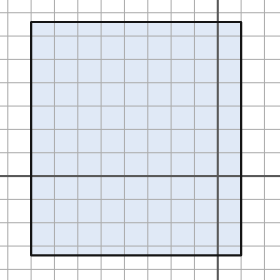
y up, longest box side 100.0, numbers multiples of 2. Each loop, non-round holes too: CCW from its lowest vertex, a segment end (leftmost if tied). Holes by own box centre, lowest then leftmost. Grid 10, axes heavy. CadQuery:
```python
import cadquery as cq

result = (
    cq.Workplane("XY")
    .moveTo(-80.0, -34.0)
    .lineTo(10.0, -34.0)
    .lineTo(10.0, 66.0)
    .lineTo(-80.0, 66.0)
    .close()
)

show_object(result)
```